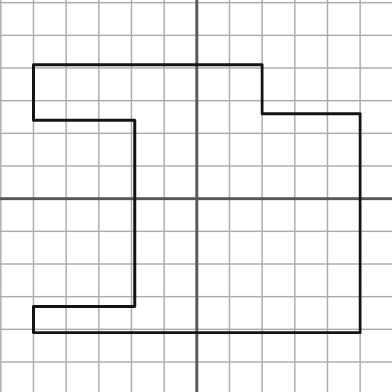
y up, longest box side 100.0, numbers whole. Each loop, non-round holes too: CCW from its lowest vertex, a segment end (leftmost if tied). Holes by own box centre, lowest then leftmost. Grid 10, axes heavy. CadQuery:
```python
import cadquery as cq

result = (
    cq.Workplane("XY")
    .moveTo(-50.0, -41.0)
    .lineTo(50.0, -41.0)
    .lineTo(50.0, 26.0)
    .lineTo(20.0, 26.0)
    .lineTo(20.0, 41.0)
    .lineTo(-50.0, 41.0)
    .lineTo(-50.0, 24.0)
    .lineTo(-19.0, 24.0)
    .lineTo(-19.0, -33.0)
    .lineTo(-50.0, -33.0)
    .close()
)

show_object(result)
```